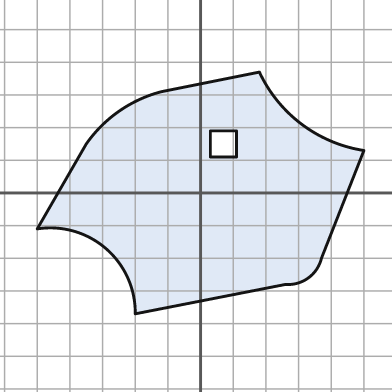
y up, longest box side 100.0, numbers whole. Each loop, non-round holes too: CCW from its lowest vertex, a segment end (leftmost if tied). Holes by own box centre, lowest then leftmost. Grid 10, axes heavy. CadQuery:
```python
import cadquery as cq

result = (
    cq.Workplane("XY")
    .moveTo(-20.0, -37.0)
    .lineTo(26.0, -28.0)
    .threePointArc((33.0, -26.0), (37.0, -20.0))
    .lineTo(50.0, 13.0)
    .threePointArc((31.0, 21.0), (18.0, 37.0))
    .lineTo(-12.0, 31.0)
    .threePointArc((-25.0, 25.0), (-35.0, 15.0))
    .lineTo(-50.0, -11.0)
    .threePointArc((-29.0, -17.0), (-20.0, -37.0))
    .close()
    .moveTo(3.0, 11.0)
    .lineTo(11.0, 11.0)
    .lineTo(11.0, 19.0)
    .lineTo(3.0, 19.0)
    .close()
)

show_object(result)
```